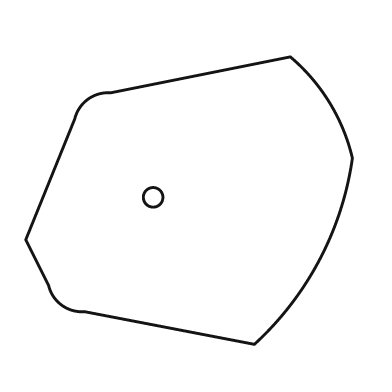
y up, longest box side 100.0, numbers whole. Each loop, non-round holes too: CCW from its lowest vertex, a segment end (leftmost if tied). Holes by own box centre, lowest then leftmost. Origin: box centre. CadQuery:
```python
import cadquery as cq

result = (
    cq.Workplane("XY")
    .moveTo(20.0, -44.0)
    .threePointArc((40.0, -18.0), (50.0, 13.0))
    .threePointArc((43.0, 30.0), (31.0, 44.0))
    .lineTo(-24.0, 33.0)
    .threePointArc((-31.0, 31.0), (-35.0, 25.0))
    .lineTo(-50.0, -12.0)
    .lineTo(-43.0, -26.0)
    .threePointArc((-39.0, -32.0), (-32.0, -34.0))
    .close()
    .moveTo(-11.0, 1.0)
    .circle(3.0)
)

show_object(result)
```